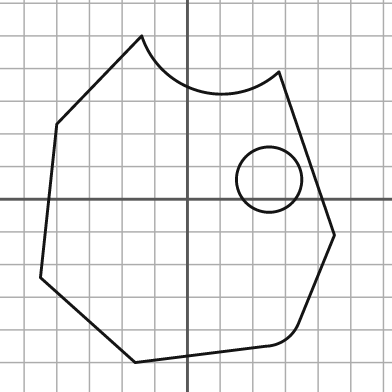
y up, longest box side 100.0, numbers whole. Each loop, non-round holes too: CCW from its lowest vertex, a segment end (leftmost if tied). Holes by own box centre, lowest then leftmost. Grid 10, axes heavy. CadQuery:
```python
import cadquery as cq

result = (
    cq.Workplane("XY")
    .moveTo(-16.0, -50.0)
    .lineTo(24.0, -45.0)
    .threePointArc((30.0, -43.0), (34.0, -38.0))
    .lineTo(45.0, -11.0)
    .lineTo(28.0, 39.0)
    .threePointArc((4.0, 33.0), (-14.0, 50.0))
    .lineTo(-40.0, 23.0)
    .lineTo(-45.0, -24.0)
    .close()
    .moveTo(25.0, 6.0)
    .circle(10.0)
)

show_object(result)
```